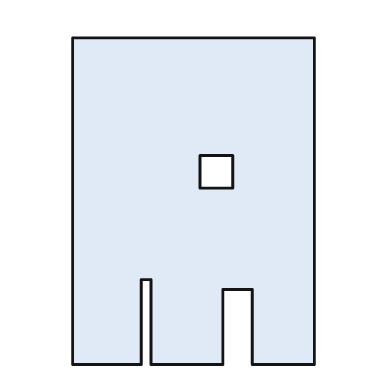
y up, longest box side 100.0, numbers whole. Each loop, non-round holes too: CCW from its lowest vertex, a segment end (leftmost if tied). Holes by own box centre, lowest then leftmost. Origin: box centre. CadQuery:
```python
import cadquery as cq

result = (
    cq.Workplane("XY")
    .moveTo(-37.0, -50.0)
    .lineTo(-16.0, -50.0)
    .lineTo(-16.0, -24.0)
    .lineTo(-13.0, -24.0)
    .lineTo(-13.0, -50.0)
    .lineTo(9.0, -50.0)
    .lineTo(9.0, -27.0)
    .lineTo(18.0, -27.0)
    .lineTo(18.0, -50.0)
    .lineTo(37.0, -50.0)
    .lineTo(37.0, 50.0)
    .lineTo(-37.0, 50.0)
    .close()
    .moveTo(2.0, 4.0)
    .lineTo(12.0, 4.0)
    .lineTo(12.0, 14.0)
    .lineTo(2.0, 14.0)
    .close()
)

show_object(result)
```